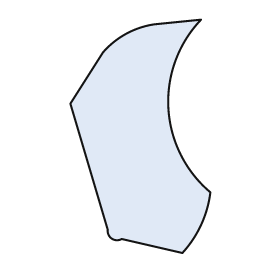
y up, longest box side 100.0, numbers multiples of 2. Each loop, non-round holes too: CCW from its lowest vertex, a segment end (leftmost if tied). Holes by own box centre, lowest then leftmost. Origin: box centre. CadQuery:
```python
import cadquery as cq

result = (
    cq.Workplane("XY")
    .moveTo(18.0, -50.0)
    .threePointArc((26.0, -38.0), (30.0, -24.0))
    .threePointArc((12.0, 12.0), (26.0, 50.0))
    .lineTo(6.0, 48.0)
    .threePointArc((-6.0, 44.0), (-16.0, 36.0))
    .lineTo(-30.0, 14.0)
    .lineTo(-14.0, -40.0)
    .threePointArc((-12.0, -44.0), (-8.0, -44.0))
    .close()
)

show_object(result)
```